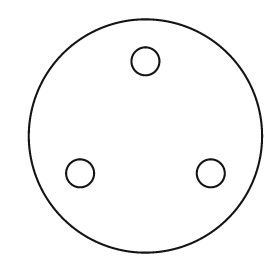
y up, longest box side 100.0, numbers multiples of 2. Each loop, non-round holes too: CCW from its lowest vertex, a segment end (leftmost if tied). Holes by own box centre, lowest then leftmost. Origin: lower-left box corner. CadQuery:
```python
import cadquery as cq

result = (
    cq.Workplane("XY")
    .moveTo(50.0, 50.0)
    .circle(50.0)
    .moveTo(22.0, 34.0)
    .circle(6.0)
    .moveTo(78.0, 34.0)
    .circle(6.0)
    .moveTo(50.0, 82.0)
    .circle(6.0)
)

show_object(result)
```